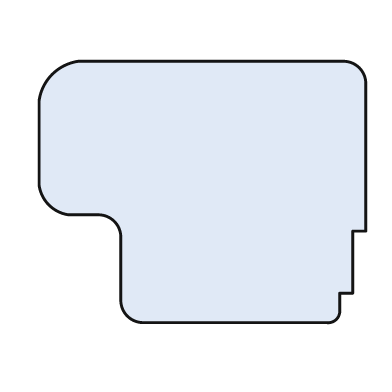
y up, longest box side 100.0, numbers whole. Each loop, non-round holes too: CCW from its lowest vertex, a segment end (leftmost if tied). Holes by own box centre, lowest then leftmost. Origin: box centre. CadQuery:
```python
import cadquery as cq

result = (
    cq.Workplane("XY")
    .moveTo(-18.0, -40.0)
    .lineTo(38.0, -40.0)
    .threePointArc((41.0, -39.0), (42.0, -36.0))
    .lineTo(42.0, -31.0)
    .lineTo(46.0, -31.0)
    .lineTo(46.0, -12.0)
    .lineTo(50.0, -12.0)
    .lineTo(50.0, 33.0)
    .threePointArc((48.0, 38.0), (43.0, 40.0))
    .lineTo(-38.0, 40.0)
    .threePointArc((-46.0, 36.0), (-50.0, 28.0))
    .lineTo(-50.0, 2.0)
    .threePointArc((-47.0, -4.0), (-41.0, -7.0))
    .lineTo(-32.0, -7.0)
    .threePointArc((-27.0, -9.0), (-25.0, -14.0))
    .lineTo(-25.0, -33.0)
    .threePointArc((-23.0, -38.0), (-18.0, -40.0))
    .close()
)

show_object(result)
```